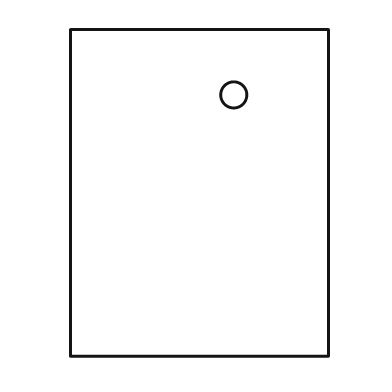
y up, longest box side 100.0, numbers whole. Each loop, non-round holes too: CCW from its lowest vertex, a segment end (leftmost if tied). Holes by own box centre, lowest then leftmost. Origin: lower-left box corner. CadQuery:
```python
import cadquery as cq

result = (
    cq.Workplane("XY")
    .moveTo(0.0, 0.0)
    .lineTo(79.0, 0.0)
    .lineTo(79.0, 100.0)
    .lineTo(0.0, 100.0)
    .close()
    .moveTo(50.0, 80.0)
    .circle(4.0)
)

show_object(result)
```